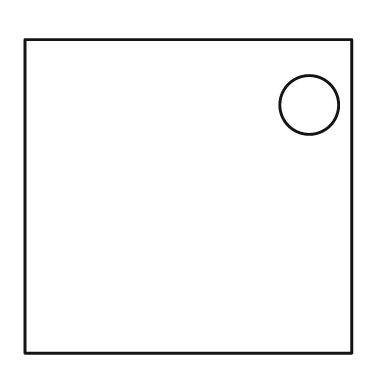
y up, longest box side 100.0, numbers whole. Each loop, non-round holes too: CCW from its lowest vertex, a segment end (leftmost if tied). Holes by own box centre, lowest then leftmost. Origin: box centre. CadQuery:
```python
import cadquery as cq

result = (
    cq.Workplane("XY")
    .moveTo(-50.0, -48.0)
    .lineTo(50.0, -48.0)
    .lineTo(50.0, 48.0)
    .lineTo(-50.0, 48.0)
    .close()
    .moveTo(37.0, 28.0)
    .circle(9.0)
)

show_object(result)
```